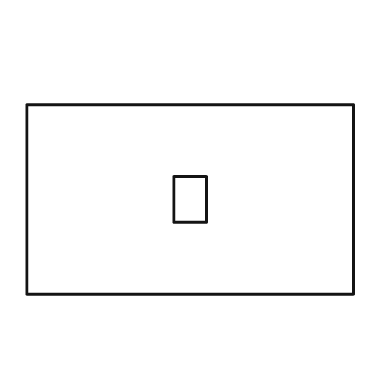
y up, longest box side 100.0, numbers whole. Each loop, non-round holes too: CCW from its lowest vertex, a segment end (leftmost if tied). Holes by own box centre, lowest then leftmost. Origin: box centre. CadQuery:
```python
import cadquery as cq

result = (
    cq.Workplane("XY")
    .moveTo(-50.0, -29.0)
    .lineTo(50.0, -29.0)
    .lineTo(50.0, 29.0)
    .lineTo(-50.0, 29.0)
    .close()
    .moveTo(-5.0, -7.0)
    .lineTo(5.0, -7.0)
    .lineTo(5.0, 7.0)
    .lineTo(-5.0, 7.0)
    .close()
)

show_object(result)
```